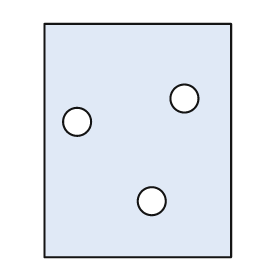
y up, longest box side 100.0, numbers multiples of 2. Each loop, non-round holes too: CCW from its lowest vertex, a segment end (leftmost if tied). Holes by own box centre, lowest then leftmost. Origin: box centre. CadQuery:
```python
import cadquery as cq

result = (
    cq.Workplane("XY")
    .moveTo(-40.0, -50.0)
    .lineTo(40.0, -50.0)
    .lineTo(40.0, 50.0)
    .lineTo(-40.0, 50.0)
    .close()
    .moveTo(6.0, -26.0)
    .circle(6.0)
    .moveTo(-26.0, 8.0)
    .circle(6.0)
    .moveTo(20.0, 18.0)
    .circle(6.0)
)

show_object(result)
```